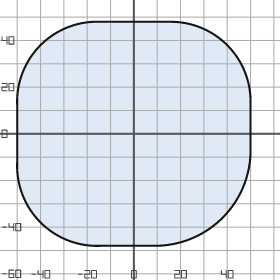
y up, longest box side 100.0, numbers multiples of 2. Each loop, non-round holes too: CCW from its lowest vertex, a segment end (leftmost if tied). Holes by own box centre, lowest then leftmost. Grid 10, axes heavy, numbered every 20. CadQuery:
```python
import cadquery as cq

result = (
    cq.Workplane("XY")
    .moveTo(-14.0, -48.0)
    .lineTo(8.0, -48.0)
    .threePointArc((38.0, -36.0), (50.0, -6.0))
    .lineTo(50.0, 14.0)
    .threePointArc((40.0, 38.0), (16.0, 48.0))
    .lineTo(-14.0, 48.0)
    .threePointArc((-40.0, 38.0), (-50.0, 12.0))
    .lineTo(-50.0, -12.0)
    .threePointArc((-40.0, -38.0), (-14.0, -48.0))
    .close()
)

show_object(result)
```